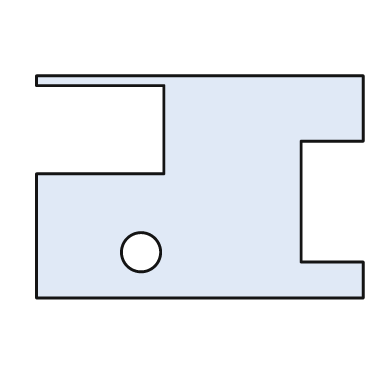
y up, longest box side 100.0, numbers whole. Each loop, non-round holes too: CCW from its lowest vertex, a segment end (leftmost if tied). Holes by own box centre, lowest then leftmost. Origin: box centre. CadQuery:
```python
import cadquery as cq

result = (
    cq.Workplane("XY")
    .moveTo(-50.0, -34.0)
    .lineTo(50.0, -34.0)
    .lineTo(50.0, -23.0)
    .lineTo(31.0, -23.0)
    .lineTo(31.0, 14.0)
    .lineTo(50.0, 14.0)
    .lineTo(50.0, 34.0)
    .lineTo(-50.0, 34.0)
    .lineTo(-50.0, 31.0)
    .lineTo(-11.0, 31.0)
    .lineTo(-11.0, 4.0)
    .lineTo(-50.0, 4.0)
    .close()
    .moveTo(-18.0, -20.0)
    .circle(6.0)
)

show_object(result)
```